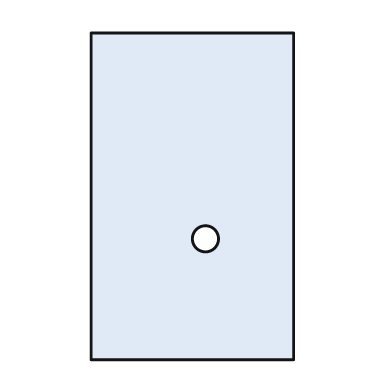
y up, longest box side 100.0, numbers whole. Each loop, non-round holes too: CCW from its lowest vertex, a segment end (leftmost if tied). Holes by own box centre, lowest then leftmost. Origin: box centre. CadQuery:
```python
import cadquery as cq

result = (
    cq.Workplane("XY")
    .moveTo(-31.0, -50.0)
    .lineTo(31.0, -50.0)
    .lineTo(31.0, 50.0)
    .lineTo(-31.0, 50.0)
    .close()
    .moveTo(4.0, -13.0)
    .circle(4.0)
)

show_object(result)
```